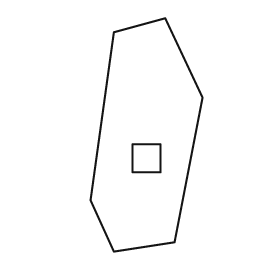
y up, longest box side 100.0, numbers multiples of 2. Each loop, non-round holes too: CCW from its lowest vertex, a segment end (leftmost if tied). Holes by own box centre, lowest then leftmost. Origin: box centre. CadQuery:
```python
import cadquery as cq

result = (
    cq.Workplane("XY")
    .moveTo(-14.0, -50.0)
    .lineTo(12.0, -46.0)
    .lineTo(24.0, 16.0)
    .lineTo(8.0, 50.0)
    .lineTo(-14.0, 44.0)
    .lineTo(-24.0, -28.0)
    .close()
    .moveTo(-6.0, -16.0)
    .lineTo(6.0, -16.0)
    .lineTo(6.0, -4.0)
    .lineTo(-6.0, -4.0)
    .close()
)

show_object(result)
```